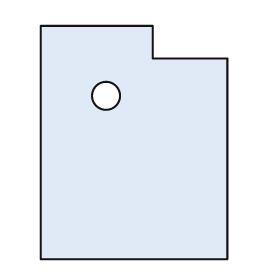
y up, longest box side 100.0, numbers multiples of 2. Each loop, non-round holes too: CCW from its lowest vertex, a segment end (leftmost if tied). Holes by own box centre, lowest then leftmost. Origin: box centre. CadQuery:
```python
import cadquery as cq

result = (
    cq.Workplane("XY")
    .moveTo(-40.0, -50.0)
    .lineTo(40.0, -50.0)
    .lineTo(40.0, 36.0)
    .lineTo(8.0, 36.0)
    .lineTo(8.0, 50.0)
    .lineTo(-40.0, 50.0)
    .close()
    .moveTo(-12.0, 20.0)
    .circle(6.0)
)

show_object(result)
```